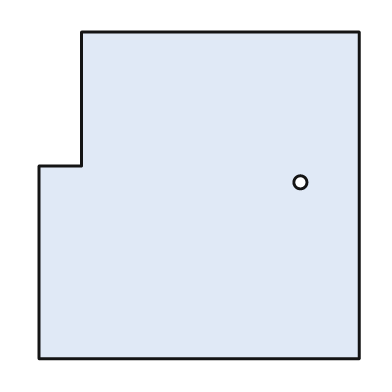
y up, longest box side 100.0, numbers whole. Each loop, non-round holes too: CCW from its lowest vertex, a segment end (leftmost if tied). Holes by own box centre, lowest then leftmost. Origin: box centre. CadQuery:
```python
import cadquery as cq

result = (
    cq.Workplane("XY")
    .moveTo(-49.0, -50.0)
    .lineTo(49.0, -50.0)
    .lineTo(49.0, 50.0)
    .lineTo(-36.0, 50.0)
    .lineTo(-36.0, 9.0)
    .lineTo(-49.0, 9.0)
    .close()
    .moveTo(31.0, 4.0)
    .circle(2.0)
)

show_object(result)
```